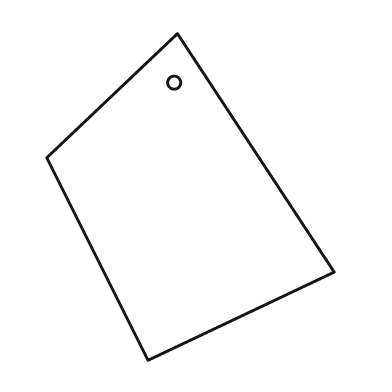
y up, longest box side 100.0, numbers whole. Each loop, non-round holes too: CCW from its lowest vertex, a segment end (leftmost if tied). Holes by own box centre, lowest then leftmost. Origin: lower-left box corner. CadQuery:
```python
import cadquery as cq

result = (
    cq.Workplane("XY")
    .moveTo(31.0, 0.0)
    .lineTo(88.0, 27.0)
    .lineTo(40.0, 100.0)
    .lineTo(0.0, 62.0)
    .close()
    .moveTo(39.0, 85.0)
    .circle(2.0)
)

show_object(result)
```